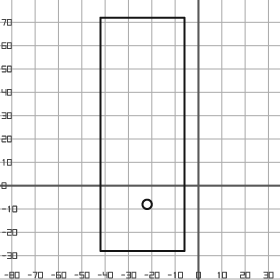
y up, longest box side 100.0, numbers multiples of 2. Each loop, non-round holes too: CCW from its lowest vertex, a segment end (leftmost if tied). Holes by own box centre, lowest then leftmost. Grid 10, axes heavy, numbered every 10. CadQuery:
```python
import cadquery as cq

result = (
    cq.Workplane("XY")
    .moveTo(-42.0, -28.0)
    .lineTo(-6.0, -28.0)
    .lineTo(-6.0, 72.0)
    .lineTo(-42.0, 72.0)
    .close()
    .moveTo(-22.0, -8.0)
    .circle(2.0)
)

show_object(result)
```